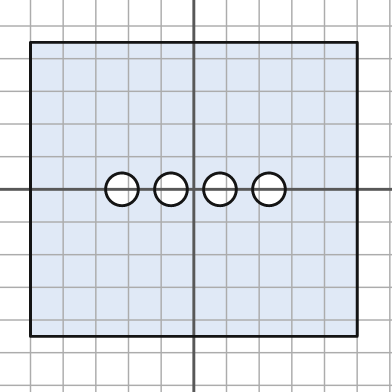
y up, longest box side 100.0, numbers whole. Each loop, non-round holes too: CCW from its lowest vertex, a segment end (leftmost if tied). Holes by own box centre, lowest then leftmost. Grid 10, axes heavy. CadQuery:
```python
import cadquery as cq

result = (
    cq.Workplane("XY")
    .moveTo(-50.0, -45.0)
    .lineTo(50.0, -45.0)
    .lineTo(50.0, 45.0)
    .lineTo(-50.0, 45.0)
    .close()
    .moveTo(-22.0, 0.0)
    .circle(5.0)
    .moveTo(-7.0, 0.0)
    .circle(5.0)
    .moveTo(8.0, 0.0)
    .circle(5.0)
    .moveTo(23.0, 0.0)
    .circle(5.0)
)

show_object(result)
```